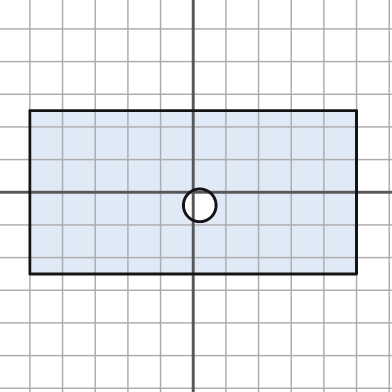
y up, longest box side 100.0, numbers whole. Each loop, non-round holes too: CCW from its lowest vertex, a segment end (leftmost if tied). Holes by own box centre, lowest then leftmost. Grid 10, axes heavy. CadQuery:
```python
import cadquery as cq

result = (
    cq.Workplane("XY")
    .moveTo(-50.0, -25.0)
    .lineTo(50.0, -25.0)
    .lineTo(50.0, 25.0)
    .lineTo(-50.0, 25.0)
    .close()
    .moveTo(2.0, -4.0)
    .circle(5.0)
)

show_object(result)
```